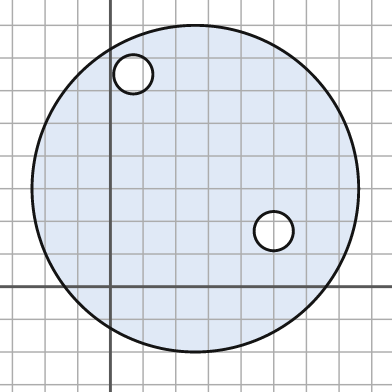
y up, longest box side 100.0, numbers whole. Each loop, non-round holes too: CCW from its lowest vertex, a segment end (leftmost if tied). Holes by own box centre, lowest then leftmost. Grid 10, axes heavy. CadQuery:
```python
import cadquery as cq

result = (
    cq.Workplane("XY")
    .moveTo(26.0, 30.0)
    .circle(50.0)
    .moveTo(50.0, 17.0)
    .circle(6.0)
    .moveTo(7.0, 65.0)
    .circle(6.0)
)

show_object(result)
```